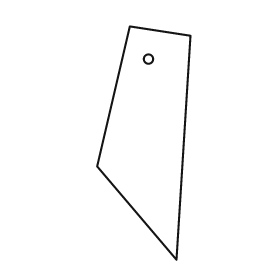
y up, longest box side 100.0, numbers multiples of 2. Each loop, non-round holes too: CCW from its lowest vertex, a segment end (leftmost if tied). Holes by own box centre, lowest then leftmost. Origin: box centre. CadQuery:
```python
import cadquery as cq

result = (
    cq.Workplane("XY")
    .moveTo(14.0, -50.0)
    .lineTo(20.0, 46.0)
    .lineTo(-6.0, 50.0)
    .lineTo(-20.0, -10.0)
    .close()
    .moveTo(2.0, 36.0)
    .circle(2.0)
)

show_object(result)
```